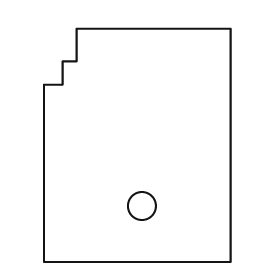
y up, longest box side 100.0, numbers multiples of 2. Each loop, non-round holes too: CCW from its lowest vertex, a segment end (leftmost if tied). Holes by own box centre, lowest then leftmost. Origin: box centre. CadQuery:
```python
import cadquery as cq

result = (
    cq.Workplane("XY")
    .moveTo(-40.0, -50.0)
    .lineTo(40.0, -50.0)
    .lineTo(40.0, 50.0)
    .lineTo(-26.0, 50.0)
    .lineTo(-26.0, 36.0)
    .lineTo(-32.0, 36.0)
    .lineTo(-32.0, 26.0)
    .lineTo(-40.0, 26.0)
    .close()
    .moveTo(2.0, -26.0)
    .circle(6.0)
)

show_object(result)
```